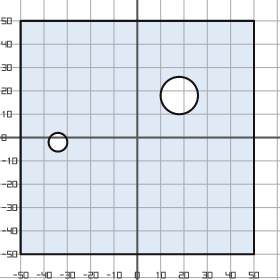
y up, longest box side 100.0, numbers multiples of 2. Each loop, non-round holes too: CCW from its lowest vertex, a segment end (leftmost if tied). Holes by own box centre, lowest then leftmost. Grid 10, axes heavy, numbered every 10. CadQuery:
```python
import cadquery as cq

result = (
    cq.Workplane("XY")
    .moveTo(-50.0, -50.0)
    .lineTo(50.0, -50.0)
    .lineTo(50.0, 50.0)
    .lineTo(-50.0, 50.0)
    .close()
    .moveTo(-34.0, -2.0)
    .circle(4.0)
    .moveTo(18.0, 18.0)
    .circle(8.0)
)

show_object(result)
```